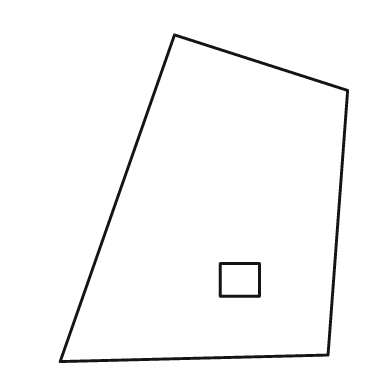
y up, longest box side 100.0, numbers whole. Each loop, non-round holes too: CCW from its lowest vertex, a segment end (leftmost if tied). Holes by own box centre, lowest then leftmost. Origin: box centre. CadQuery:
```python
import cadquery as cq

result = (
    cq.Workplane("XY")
    .moveTo(-44.0, -50.0)
    .lineTo(38.0, -48.0)
    .lineTo(44.0, 33.0)
    .lineTo(-9.0, 50.0)
    .close()
    .moveTo(5.0, -30.0)
    .lineTo(17.0, -30.0)
    .lineTo(17.0, -20.0)
    .lineTo(5.0, -20.0)
    .close()
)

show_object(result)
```